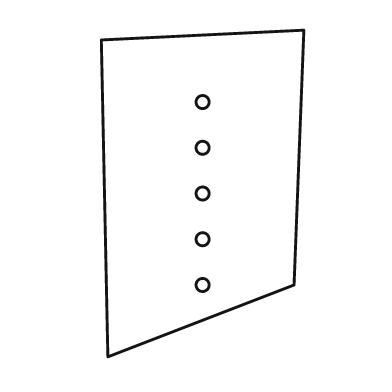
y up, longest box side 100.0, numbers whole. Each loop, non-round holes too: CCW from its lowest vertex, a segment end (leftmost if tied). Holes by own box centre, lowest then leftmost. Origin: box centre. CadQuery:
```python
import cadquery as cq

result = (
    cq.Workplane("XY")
    .moveTo(-29.0, -50.0)
    .lineTo(28.0, -28.0)
    .lineTo(31.0, 50.0)
    .lineTo(-31.0, 47.0)
    .close()
    .moveTo(0.0, -28.0)
    .circle(2.0)
    .moveTo(0.0, -14.0)
    .circle(2.0)
    .moveTo(0.0, 0.0)
    .circle(2.0)
    .moveTo(0.0, 14.0)
    .circle(2.0)
    .moveTo(0.0, 28.0)
    .circle(2.0)
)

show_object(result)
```